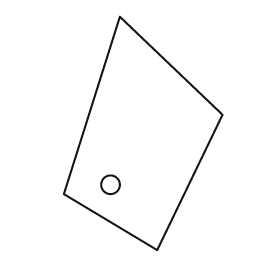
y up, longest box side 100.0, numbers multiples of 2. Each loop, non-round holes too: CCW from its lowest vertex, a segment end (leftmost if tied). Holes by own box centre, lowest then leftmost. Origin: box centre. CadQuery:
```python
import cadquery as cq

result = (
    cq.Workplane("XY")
    .moveTo(6.0, -50.0)
    .lineTo(34.0, 8.0)
    .lineTo(-10.0, 50.0)
    .lineTo(-34.0, -26.0)
    .close()
    .moveTo(-14.0, -22.0)
    .circle(4.0)
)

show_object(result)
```